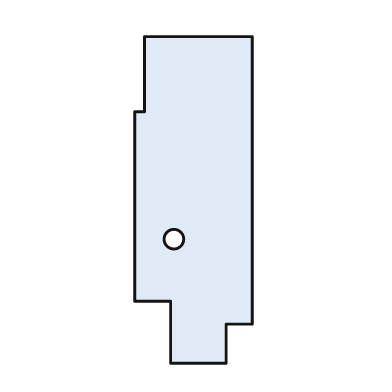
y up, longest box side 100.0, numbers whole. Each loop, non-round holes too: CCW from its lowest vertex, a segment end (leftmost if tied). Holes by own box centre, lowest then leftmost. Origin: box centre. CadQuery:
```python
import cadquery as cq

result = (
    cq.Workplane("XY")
    .moveTo(-7.0, -50.0)
    .lineTo(10.0, -50.0)
    .lineTo(10.0, -38.0)
    .lineTo(18.0, -38.0)
    .lineTo(18.0, 50.0)
    .lineTo(-15.0, 50.0)
    .lineTo(-15.0, 27.0)
    .lineTo(-18.0, 27.0)
    .lineTo(-18.0, -31.0)
    .lineTo(-7.0, -31.0)
    .close()
    .moveTo(-6.0, -12.0)
    .circle(3.0)
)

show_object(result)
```